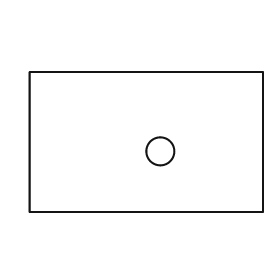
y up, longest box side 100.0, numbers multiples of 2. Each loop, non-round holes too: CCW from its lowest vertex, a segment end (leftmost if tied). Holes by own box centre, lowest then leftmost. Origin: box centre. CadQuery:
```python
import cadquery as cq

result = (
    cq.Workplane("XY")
    .moveTo(-50.0, -30.0)
    .lineTo(50.0, -30.0)
    .lineTo(50.0, 30.0)
    .lineTo(-50.0, 30.0)
    .close()
    .moveTo(6.0, -4.0)
    .circle(6.0)
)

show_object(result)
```